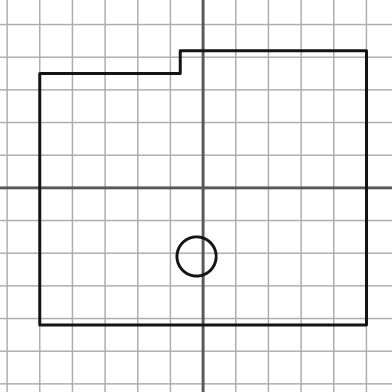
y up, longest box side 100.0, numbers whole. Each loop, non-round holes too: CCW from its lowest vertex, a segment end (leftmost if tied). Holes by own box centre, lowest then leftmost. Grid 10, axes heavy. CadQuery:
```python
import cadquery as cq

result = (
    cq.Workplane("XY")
    .moveTo(-50.0, -42.0)
    .lineTo(50.0, -42.0)
    .lineTo(50.0, 42.0)
    .lineTo(-7.0, 42.0)
    .lineTo(-7.0, 35.0)
    .lineTo(-50.0, 35.0)
    .close()
    .moveTo(-2.0, -21.0)
    .circle(6.0)
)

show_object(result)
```